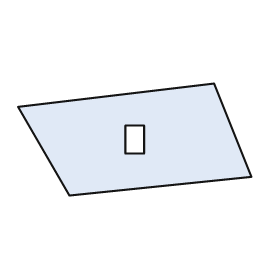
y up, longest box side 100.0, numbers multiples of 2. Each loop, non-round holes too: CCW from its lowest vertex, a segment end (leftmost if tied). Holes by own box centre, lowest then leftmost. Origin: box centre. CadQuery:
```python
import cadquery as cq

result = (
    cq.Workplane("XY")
    .moveTo(-28.0, -24.0)
    .lineTo(50.0, -16.0)
    .lineTo(34.0, 24.0)
    .lineTo(-50.0, 14.0)
    .close()
    .moveTo(-4.0, -6.0)
    .lineTo(4.0, -6.0)
    .lineTo(4.0, 6.0)
    .lineTo(-4.0, 6.0)
    .close()
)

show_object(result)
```